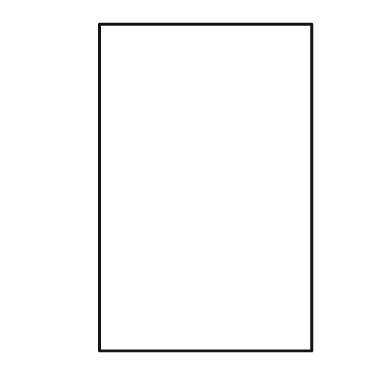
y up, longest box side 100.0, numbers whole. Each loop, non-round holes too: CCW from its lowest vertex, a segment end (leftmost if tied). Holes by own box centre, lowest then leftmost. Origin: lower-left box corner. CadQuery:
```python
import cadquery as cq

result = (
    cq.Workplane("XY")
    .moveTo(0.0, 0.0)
    .lineTo(65.0, 0.0)
    .lineTo(65.0, 100.0)
    .lineTo(0.0, 100.0)
    .close()
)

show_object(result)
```